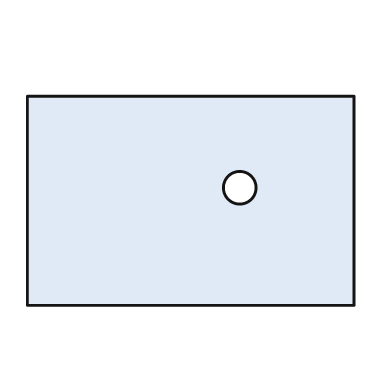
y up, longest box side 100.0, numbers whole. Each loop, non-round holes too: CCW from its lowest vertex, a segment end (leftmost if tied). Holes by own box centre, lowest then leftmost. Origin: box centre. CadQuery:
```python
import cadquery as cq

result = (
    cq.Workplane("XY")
    .moveTo(-50.0, -32.0)
    .lineTo(50.0, -32.0)
    .lineTo(50.0, 32.0)
    .lineTo(-50.0, 32.0)
    .close()
    .moveTo(15.0, 4.0)
    .circle(5.0)
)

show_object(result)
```